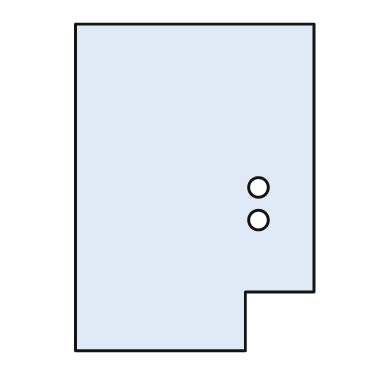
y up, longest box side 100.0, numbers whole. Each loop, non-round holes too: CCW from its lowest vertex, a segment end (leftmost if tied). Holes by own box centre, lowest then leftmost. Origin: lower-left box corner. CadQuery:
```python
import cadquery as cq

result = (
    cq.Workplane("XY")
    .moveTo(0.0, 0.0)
    .lineTo(52.0, 0.0)
    .lineTo(52.0, 18.0)
    .lineTo(73.0, 18.0)
    .lineTo(73.0, 100.0)
    .lineTo(0.0, 100.0)
    .close()
    .moveTo(56.0, 40.0)
    .circle(3.0)
    .moveTo(56.0, 50.0)
    .circle(3.0)
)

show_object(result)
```